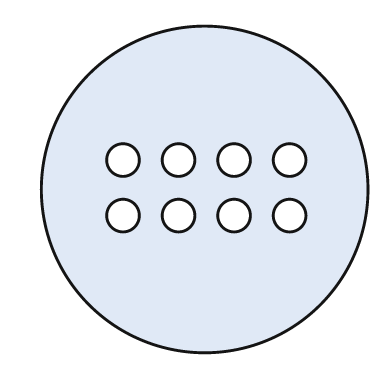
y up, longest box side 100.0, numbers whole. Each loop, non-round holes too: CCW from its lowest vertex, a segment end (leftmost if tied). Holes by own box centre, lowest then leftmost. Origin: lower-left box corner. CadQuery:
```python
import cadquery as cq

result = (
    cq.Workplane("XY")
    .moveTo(50.0, 50.0)
    .circle(50.0)
    .moveTo(25.0, 42.0)
    .circle(5.0)
    .moveTo(42.0, 42.0)
    .circle(5.0)
    .moveTo(59.0, 42.0)
    .circle(5.0)
    .moveTo(76.0, 42.0)
    .circle(5.0)
    .moveTo(25.0, 59.0)
    .circle(5.0)
    .moveTo(42.0, 59.0)
    .circle(5.0)
    .moveTo(59.0, 59.0)
    .circle(5.0)
    .moveTo(76.0, 59.0)
    .circle(5.0)
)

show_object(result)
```